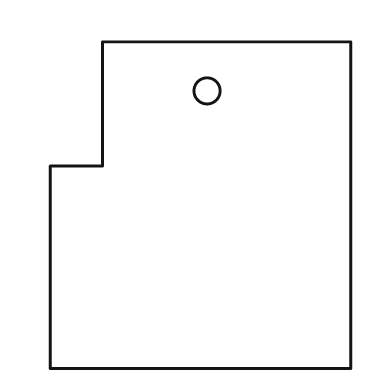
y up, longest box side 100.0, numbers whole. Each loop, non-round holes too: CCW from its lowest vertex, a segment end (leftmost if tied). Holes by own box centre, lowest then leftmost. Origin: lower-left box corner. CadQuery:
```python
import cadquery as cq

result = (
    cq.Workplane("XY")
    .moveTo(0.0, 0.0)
    .lineTo(92.0, 0.0)
    .lineTo(92.0, 100.0)
    .lineTo(16.0, 100.0)
    .lineTo(16.0, 62.0)
    .lineTo(0.0, 62.0)
    .close()
    .moveTo(48.0, 85.0)
    .circle(4.0)
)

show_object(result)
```